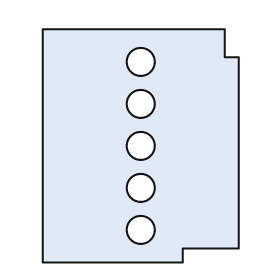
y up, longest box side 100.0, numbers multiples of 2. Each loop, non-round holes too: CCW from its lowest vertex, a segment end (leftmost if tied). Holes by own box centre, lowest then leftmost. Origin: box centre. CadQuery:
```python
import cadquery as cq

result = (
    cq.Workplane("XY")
    .moveTo(-42.0, -50.0)
    .lineTo(18.0, -50.0)
    .lineTo(18.0, -44.0)
    .lineTo(42.0, -44.0)
    .lineTo(42.0, 38.0)
    .lineTo(36.0, 38.0)
    .lineTo(36.0, 50.0)
    .lineTo(-42.0, 50.0)
    .close()
    .moveTo(0.0, -36.0)
    .circle(6.0)
    .moveTo(0.0, -18.0)
    .circle(6.0)
    .moveTo(0.0, 0.0)
    .circle(6.0)
    .moveTo(0.0, 18.0)
    .circle(6.0)
    .moveTo(0.0, 36.0)
    .circle(6.0)
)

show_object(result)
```